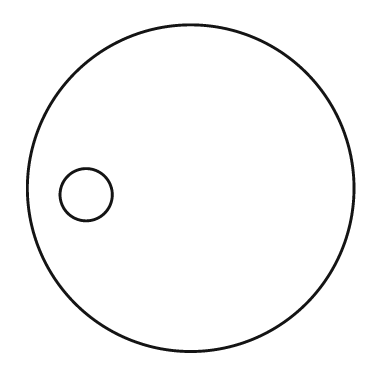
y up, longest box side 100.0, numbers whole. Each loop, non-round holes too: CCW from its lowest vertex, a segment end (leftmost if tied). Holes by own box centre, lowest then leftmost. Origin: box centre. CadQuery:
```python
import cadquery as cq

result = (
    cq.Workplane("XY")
    .moveTo(0.0, 0.0)
    .circle(50.0)
    .moveTo(-32.0, -2.0)
    .circle(8.0)
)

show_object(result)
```